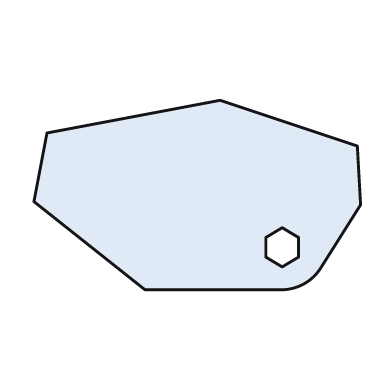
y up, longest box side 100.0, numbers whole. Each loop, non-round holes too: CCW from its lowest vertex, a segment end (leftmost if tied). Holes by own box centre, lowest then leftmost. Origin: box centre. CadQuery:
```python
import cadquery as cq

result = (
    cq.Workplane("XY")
    .moveTo(-16.0, -29.0)
    .lineTo(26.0, -29.0)
    .threePointArc((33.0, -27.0), (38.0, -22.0))
    .lineTo(50.0, -3.0)
    .lineTo(49.0, 15.0)
    .lineTo(7.0, 29.0)
    .lineTo(-46.0, 19.0)
    .lineTo(-50.0, -2.0)
    .close()
    .moveTo(26.0, -22.0)
    .lineTo(31.0, -19.0)
    .lineTo(31.0, -13.0)
    .lineTo(26.0, -10.0)
    .lineTo(21.0, -13.0)
    .lineTo(21.0, -19.0)
    .close()
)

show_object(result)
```